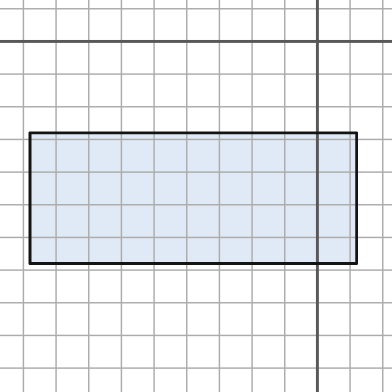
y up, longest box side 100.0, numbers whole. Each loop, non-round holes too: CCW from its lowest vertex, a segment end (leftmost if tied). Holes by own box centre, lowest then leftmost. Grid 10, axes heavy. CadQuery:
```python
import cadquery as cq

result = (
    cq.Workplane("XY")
    .moveTo(-88.0, -68.0)
    .lineTo(12.0, -68.0)
    .lineTo(12.0, -28.0)
    .lineTo(-88.0, -28.0)
    .close()
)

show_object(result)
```